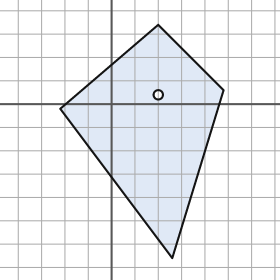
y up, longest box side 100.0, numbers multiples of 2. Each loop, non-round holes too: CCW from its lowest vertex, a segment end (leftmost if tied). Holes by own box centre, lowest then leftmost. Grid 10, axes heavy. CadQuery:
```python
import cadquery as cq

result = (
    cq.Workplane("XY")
    .moveTo(26.0, -66.0)
    .lineTo(48.0, 6.0)
    .lineTo(20.0, 34.0)
    .lineTo(-22.0, -2.0)
    .close()
    .moveTo(20.0, 4.0)
    .circle(2.0)
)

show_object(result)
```